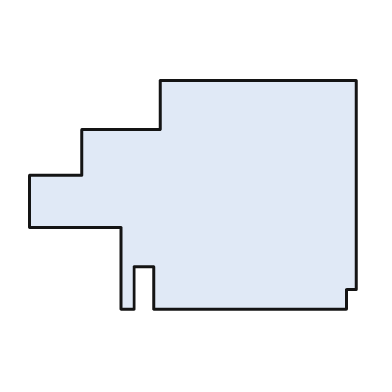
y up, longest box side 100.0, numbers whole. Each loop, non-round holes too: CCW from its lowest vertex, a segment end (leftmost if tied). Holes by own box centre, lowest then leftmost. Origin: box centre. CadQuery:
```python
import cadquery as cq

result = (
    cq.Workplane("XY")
    .moveTo(-22.0, -35.0)
    .lineTo(-18.0, -35.0)
    .lineTo(-18.0, -22.0)
    .lineTo(-12.0, -22.0)
    .lineTo(-12.0, -35.0)
    .lineTo(47.0, -35.0)
    .lineTo(47.0, -29.0)
    .lineTo(50.0, -29.0)
    .lineTo(50.0, 35.0)
    .lineTo(-10.0, 35.0)
    .lineTo(-10.0, 20.0)
    .lineTo(-34.0, 20.0)
    .lineTo(-34.0, 6.0)
    .lineTo(-50.0, 6.0)
    .lineTo(-50.0, -10.0)
    .lineTo(-22.0, -10.0)
    .close()
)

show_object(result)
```